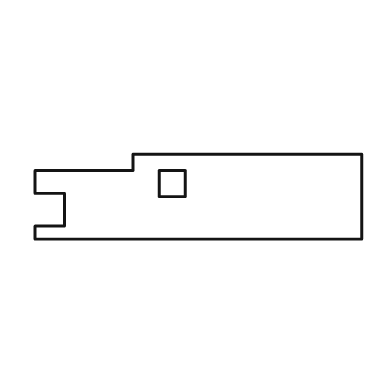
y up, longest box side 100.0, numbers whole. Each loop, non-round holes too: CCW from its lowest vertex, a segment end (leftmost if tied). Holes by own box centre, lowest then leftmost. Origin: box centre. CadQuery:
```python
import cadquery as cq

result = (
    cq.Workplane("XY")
    .moveTo(-50.0, -13.0)
    .lineTo(50.0, -13.0)
    .lineTo(50.0, 13.0)
    .lineTo(-20.0, 13.0)
    .lineTo(-20.0, 8.0)
    .lineTo(-50.0, 8.0)
    .lineTo(-50.0, 1.0)
    .lineTo(-41.0, 1.0)
    .lineTo(-41.0, -9.0)
    .lineTo(-50.0, -9.0)
    .close()
    .moveTo(-12.0, 0.0)
    .lineTo(-4.0, 0.0)
    .lineTo(-4.0, 8.0)
    .lineTo(-12.0, 8.0)
    .close()
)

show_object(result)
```